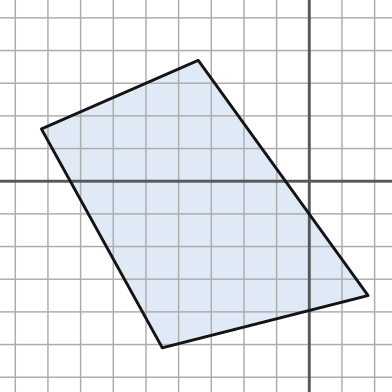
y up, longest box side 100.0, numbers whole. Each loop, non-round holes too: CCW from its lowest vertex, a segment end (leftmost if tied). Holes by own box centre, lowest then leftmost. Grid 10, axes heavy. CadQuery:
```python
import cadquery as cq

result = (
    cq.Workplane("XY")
    .moveTo(-45.0, -51.0)
    .lineTo(18.0, -35.0)
    .lineTo(-34.0, 37.0)
    .lineTo(-82.0, 16.0)
    .close()
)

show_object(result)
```